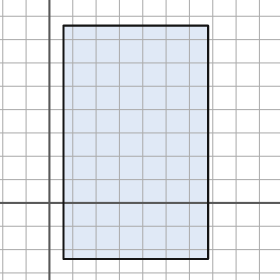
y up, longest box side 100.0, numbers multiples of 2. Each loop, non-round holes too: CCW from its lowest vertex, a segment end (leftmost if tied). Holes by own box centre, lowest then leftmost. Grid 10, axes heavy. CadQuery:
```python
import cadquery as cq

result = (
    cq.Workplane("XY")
    .moveTo(6.0, -24.0)
    .lineTo(68.0, -24.0)
    .lineTo(68.0, 76.0)
    .lineTo(6.0, 76.0)
    .close()
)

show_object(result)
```